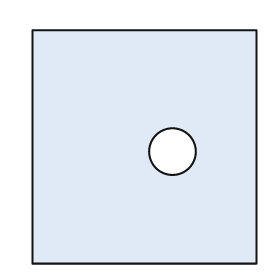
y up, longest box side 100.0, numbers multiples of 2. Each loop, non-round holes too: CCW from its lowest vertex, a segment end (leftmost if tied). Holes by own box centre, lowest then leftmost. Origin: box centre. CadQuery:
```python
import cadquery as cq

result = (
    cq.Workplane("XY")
    .moveTo(-48.0, -50.0)
    .lineTo(48.0, -50.0)
    .lineTo(48.0, 50.0)
    .lineTo(-48.0, 50.0)
    .close()
    .moveTo(12.0, -2.0)
    .circle(10.0)
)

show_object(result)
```